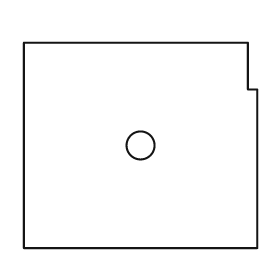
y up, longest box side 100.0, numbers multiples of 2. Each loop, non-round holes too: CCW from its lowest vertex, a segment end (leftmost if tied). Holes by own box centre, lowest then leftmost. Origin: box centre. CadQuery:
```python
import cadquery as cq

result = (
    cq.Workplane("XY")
    .moveTo(-50.0, -44.0)
    .lineTo(50.0, -44.0)
    .lineTo(50.0, 24.0)
    .lineTo(46.0, 24.0)
    .lineTo(46.0, 44.0)
    .lineTo(-50.0, 44.0)
    .close()
    .moveTo(0.0, 0.0)
    .circle(6.0)
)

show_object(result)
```